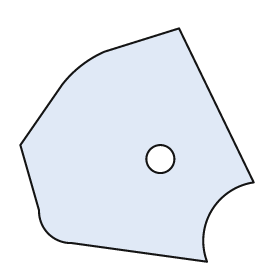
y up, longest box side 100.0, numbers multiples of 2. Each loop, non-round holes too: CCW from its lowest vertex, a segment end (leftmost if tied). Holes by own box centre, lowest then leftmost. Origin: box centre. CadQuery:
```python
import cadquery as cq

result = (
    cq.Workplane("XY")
    .moveTo(30.0, -50.0)
    .threePointArc((32.0, -28.0), (50.0, -16.0))
    .lineTo(18.0, 50.0)
    .lineTo(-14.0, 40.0)
    .threePointArc((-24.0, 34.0), (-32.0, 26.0))
    .lineTo(-50.0, 0.0)
    .lineTo(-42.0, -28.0)
    .threePointArc((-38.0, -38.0), (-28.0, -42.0))
    .close()
    .moveTo(10.0, -6.0)
    .circle(6.0)
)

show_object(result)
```